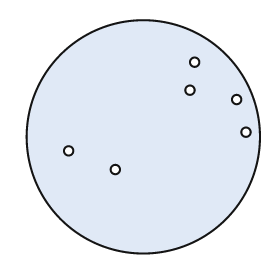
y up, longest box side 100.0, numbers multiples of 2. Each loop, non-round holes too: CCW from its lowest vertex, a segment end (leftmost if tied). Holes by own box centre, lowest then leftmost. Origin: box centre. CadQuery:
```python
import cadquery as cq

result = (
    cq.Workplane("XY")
    .moveTo(0.0, 0.0)
    .circle(50.0)
    .moveTo(-12.0, -14.0)
    .circle(2.0)
    .moveTo(-32.0, -6.0)
    .circle(2.0)
    .moveTo(44.0, 2.0)
    .circle(2.0)
    .moveTo(40.0, 16.0)
    .circle(2.0)
    .moveTo(20.0, 20.0)
    .circle(2.0)
    .moveTo(22.0, 32.0)
    .circle(2.0)
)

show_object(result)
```